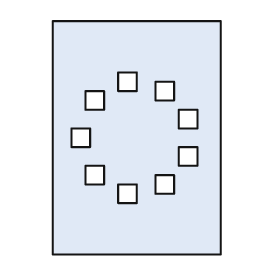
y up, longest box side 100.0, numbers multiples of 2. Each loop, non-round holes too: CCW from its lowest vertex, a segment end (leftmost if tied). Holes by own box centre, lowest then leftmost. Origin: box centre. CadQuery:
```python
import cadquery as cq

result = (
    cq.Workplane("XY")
    .moveTo(-36.0, -50.0)
    .lineTo(36.0, -50.0)
    .lineTo(36.0, 50.0)
    .lineTo(-36.0, 50.0)
    .close()
    .moveTo(-8.0, -28.0)
    .lineTo(0.0, -28.0)
    .lineTo(0.0, -20.0)
    .lineTo(-8.0, -20.0)
    .close()
    .moveTo(8.0, -24.0)
    .lineTo(16.0, -24.0)
    .lineTo(16.0, -16.0)
    .lineTo(8.0, -16.0)
    .close()
    .moveTo(-22.0, -20.0)
    .lineTo(-14.0, -20.0)
    .lineTo(-14.0, -12.0)
    .lineTo(-22.0, -12.0)
    .close()
    .moveTo(18.0, -12.0)
    .lineTo(26.0, -12.0)
    .lineTo(26.0, -4.0)
    .lineTo(18.0, -4.0)
    .close()
    .moveTo(-28.0, -4.0)
    .lineTo(-20.0, -4.0)
    .lineTo(-20.0, 4.0)
    .lineTo(-28.0, 4.0)
    .close()
    .moveTo(18.0, 4.0)
    .lineTo(26.0, 4.0)
    .lineTo(26.0, 12.0)
    .lineTo(18.0, 12.0)
    .close()
    .moveTo(-22.0, 12.0)
    .lineTo(-14.0, 12.0)
    .lineTo(-14.0, 20.0)
    .lineTo(-22.0, 20.0)
    .close()
    .moveTo(8.0, 16.0)
    .lineTo(16.0, 16.0)
    .lineTo(16.0, 24.0)
    .lineTo(8.0, 24.0)
    .close()
    .moveTo(-8.0, 20.0)
    .lineTo(0.0, 20.0)
    .lineTo(0.0, 28.0)
    .lineTo(-8.0, 28.0)
    .close()
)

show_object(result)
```